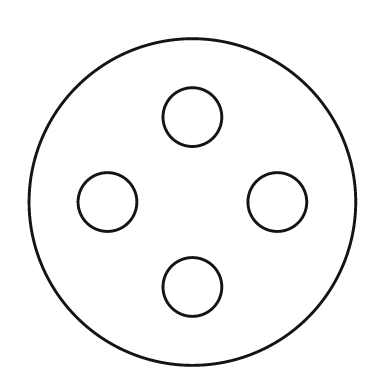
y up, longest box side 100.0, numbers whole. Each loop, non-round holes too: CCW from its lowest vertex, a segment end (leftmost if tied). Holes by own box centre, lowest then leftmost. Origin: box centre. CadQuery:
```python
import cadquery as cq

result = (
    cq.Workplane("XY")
    .moveTo(0.0, 0.0)
    .circle(50.0)
    .moveTo(0.0, -26.0)
    .circle(9.0)
    .moveTo(-26.0, 0.0)
    .circle(9.0)
    .moveTo(26.0, 0.0)
    .circle(9.0)
    .moveTo(0.0, 26.0)
    .circle(9.0)
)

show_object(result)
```